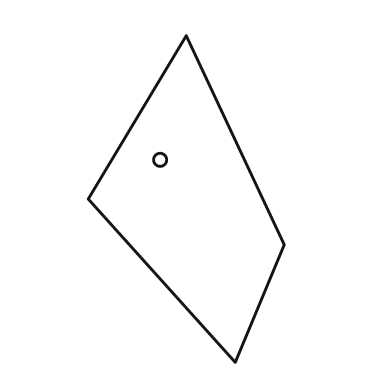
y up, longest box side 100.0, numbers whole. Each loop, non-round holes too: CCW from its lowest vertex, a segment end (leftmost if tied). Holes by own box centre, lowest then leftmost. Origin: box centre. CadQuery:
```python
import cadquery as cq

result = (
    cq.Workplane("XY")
    .moveTo(15.0, -50.0)
    .lineTo(30.0, -14.0)
    .lineTo(0.0, 50.0)
    .lineTo(-30.0, 0.0)
    .close()
    .moveTo(-8.0, 12.0)
    .circle(2.0)
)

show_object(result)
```